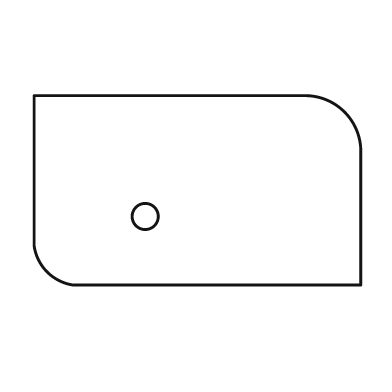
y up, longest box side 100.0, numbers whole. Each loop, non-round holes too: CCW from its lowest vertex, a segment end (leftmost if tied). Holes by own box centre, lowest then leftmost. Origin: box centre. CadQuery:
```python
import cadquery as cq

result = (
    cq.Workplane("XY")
    .moveTo(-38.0, -29.0)
    .lineTo(50.0, -29.0)
    .lineTo(50.0, 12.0)
    .threePointArc((45.0, 24.0), (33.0, 29.0))
    .lineTo(-50.0, 29.0)
    .lineTo(-50.0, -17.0)
    .threePointArc((-46.0, -25.0), (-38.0, -29.0))
    .close()
    .moveTo(-16.0, -8.0)
    .circle(4.0)
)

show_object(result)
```